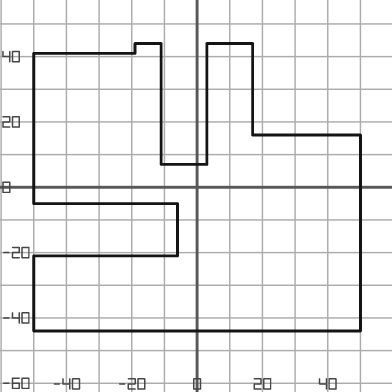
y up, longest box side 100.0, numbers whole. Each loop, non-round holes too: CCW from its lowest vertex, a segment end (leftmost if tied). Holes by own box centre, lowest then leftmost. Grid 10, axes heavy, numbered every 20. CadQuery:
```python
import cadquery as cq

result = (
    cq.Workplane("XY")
    .moveTo(-50.0, -44.0)
    .lineTo(50.0, -44.0)
    .lineTo(50.0, 16.0)
    .lineTo(17.0, 16.0)
    .lineTo(17.0, 44.0)
    .lineTo(3.0, 44.0)
    .lineTo(3.0, 7.0)
    .lineTo(-11.0, 7.0)
    .lineTo(-11.0, 44.0)
    .lineTo(-19.0, 44.0)
    .lineTo(-19.0, 41.0)
    .lineTo(-50.0, 41.0)
    .lineTo(-50.0, -5.0)
    .lineTo(-6.0, -5.0)
    .lineTo(-6.0, -21.0)
    .lineTo(-50.0, -21.0)
    .close()
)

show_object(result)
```